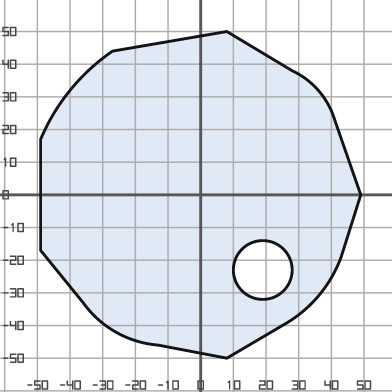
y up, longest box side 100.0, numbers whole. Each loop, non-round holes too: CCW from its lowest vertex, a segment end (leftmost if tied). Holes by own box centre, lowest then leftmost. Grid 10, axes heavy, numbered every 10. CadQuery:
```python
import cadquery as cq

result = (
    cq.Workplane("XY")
    .moveTo(8.0, -50.0)
    .lineTo(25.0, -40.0)
    .threePointArc((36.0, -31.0), (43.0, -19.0))
    .lineTo(49.0, 0.0)
    .lineTo(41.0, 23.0)
    .threePointArc((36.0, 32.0), (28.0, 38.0))
    .lineTo(8.0, 50.0)
    .lineTo(-27.0, 44.0)
    .threePointArc((-40.0, 32.0), (-49.0, 17.0))
    .lineTo(-49.0, -17.0)
    .lineTo(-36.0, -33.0)
    .threePointArc((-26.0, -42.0), (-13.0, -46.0))
    .close()
    .moveTo(19.0, -23.0)
    .circle(9.0)
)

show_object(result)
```